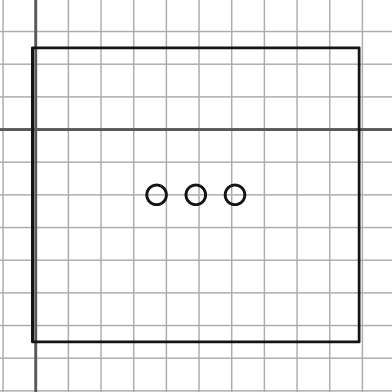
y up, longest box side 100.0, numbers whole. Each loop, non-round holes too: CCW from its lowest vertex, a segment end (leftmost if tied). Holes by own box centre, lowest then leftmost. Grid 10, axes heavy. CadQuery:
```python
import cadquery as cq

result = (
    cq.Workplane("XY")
    .moveTo(-1.0, -65.0)
    .lineTo(99.0, -65.0)
    .lineTo(99.0, 25.0)
    .lineTo(-1.0, 25.0)
    .close()
    .moveTo(37.0, -20.0)
    .circle(3.0)
    .moveTo(49.0, -20.0)
    .circle(3.0)
    .moveTo(61.0, -20.0)
    .circle(3.0)
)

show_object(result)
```